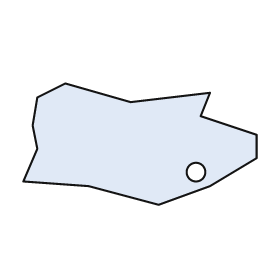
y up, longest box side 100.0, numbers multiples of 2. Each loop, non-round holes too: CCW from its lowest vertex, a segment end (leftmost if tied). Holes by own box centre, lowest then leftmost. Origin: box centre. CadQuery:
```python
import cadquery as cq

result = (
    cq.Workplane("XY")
    .moveTo(8.0, -26.0)
    .lineTo(30.0, -18.0)
    .lineTo(50.0, -6.0)
    .lineTo(50.0, 4.0)
    .lineTo(26.0, 12.0)
    .lineTo(30.0, 22.0)
    .lineTo(-4.0, 18.0)
    .lineTo(-32.0, 26.0)
    .lineTo(-44.0, 20.0)
    .lineTo(-46.0, 8.0)
    .lineTo(-44.0, -2.0)
    .lineTo(-50.0, -16.0)
    .lineTo(-22.0, -18.0)
    .close()
    .moveTo(24.0, -12.0)
    .circle(4.0)
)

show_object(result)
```